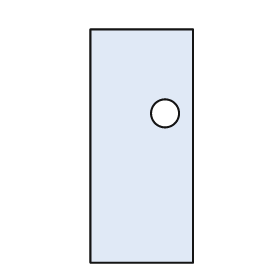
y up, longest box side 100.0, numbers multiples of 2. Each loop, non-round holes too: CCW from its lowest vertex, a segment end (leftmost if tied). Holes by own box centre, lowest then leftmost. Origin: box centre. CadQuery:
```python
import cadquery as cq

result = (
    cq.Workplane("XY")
    .moveTo(-22.0, -50.0)
    .lineTo(22.0, -50.0)
    .lineTo(22.0, 50.0)
    .lineTo(-22.0, 50.0)
    .close()
    .moveTo(10.0, 14.0)
    .circle(6.0)
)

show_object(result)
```